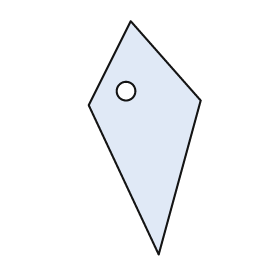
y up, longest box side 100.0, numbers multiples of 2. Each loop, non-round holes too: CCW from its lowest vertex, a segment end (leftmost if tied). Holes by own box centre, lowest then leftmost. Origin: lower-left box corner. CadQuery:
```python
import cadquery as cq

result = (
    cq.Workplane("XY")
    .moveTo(30.0, 0.0)
    .lineTo(48.0, 66.0)
    .lineTo(18.0, 100.0)
    .lineTo(0.0, 64.0)
    .close()
    .moveTo(16.0, 70.0)
    .circle(4.0)
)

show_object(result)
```